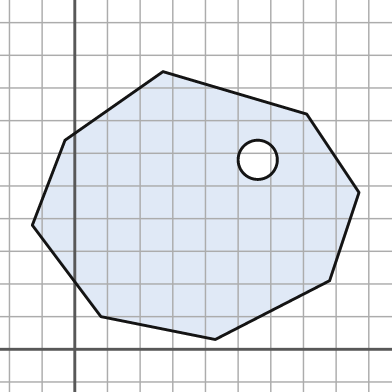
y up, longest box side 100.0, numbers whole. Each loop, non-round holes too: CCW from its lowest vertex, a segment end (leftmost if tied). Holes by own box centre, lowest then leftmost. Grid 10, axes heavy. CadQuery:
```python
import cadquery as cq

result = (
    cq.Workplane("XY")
    .moveTo(43.0, 3.0)
    .lineTo(78.0, 21.0)
    .lineTo(87.0, 48.0)
    .lineTo(71.0, 72.0)
    .lineTo(27.0, 85.0)
    .lineTo(-3.0, 64.0)
    .lineTo(-13.0, 38.0)
    .lineTo(8.0, 10.0)
    .close()
    .moveTo(56.0, 58.0)
    .circle(6.0)
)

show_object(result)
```